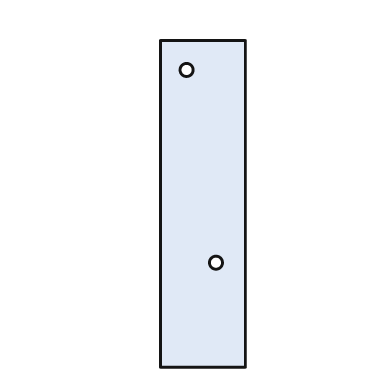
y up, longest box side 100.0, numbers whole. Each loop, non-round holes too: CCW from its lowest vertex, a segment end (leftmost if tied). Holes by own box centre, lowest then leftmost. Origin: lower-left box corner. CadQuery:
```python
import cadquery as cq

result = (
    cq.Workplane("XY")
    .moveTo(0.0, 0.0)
    .lineTo(26.0, 0.0)
    .lineTo(26.0, 100.0)
    .lineTo(0.0, 100.0)
    .close()
    .moveTo(17.0, 32.0)
    .circle(2.0)
    .moveTo(8.0, 91.0)
    .circle(2.0)
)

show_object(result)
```